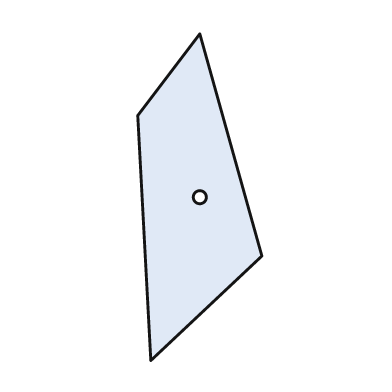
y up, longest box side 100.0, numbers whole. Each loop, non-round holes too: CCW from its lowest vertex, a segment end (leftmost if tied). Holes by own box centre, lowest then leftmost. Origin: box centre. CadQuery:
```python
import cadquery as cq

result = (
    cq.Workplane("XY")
    .moveTo(-15.0, -50.0)
    .lineTo(19.0, -18.0)
    .lineTo(0.0, 50.0)
    .lineTo(-19.0, 25.0)
    .close()
    .moveTo(0.0, 0.0)
    .circle(2.0)
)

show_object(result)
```